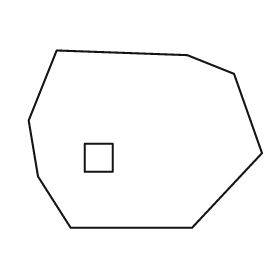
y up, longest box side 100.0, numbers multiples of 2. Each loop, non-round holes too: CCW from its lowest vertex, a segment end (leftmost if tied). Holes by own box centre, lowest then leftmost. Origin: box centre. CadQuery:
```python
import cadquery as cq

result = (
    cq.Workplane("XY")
    .moveTo(-32.0, -38.0)
    .lineTo(20.0, -38.0)
    .lineTo(50.0, -6.0)
    .lineTo(38.0, 28.0)
    .lineTo(18.0, 36.0)
    .lineTo(-38.0, 38.0)
    .lineTo(-50.0, 8.0)
    .lineTo(-46.0, -16.0)
    .close()
    .moveTo(-26.0, -14.0)
    .lineTo(-14.0, -14.0)
    .lineTo(-14.0, -2.0)
    .lineTo(-26.0, -2.0)
    .close()
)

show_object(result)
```